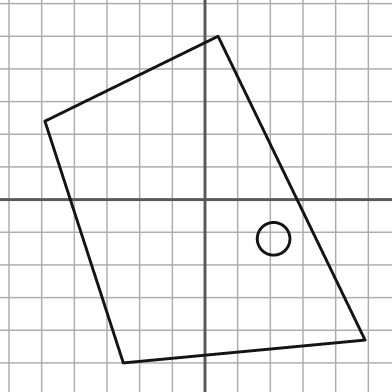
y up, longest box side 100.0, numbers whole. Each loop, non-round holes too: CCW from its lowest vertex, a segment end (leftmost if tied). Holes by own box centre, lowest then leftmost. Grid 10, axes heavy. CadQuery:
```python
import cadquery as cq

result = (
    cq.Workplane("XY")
    .moveTo(-25.0, -50.0)
    .lineTo(49.0, -43.0)
    .lineTo(4.0, 50.0)
    .lineTo(-49.0, 24.0)
    .close()
    .moveTo(21.0, -12.0)
    .circle(5.0)
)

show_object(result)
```